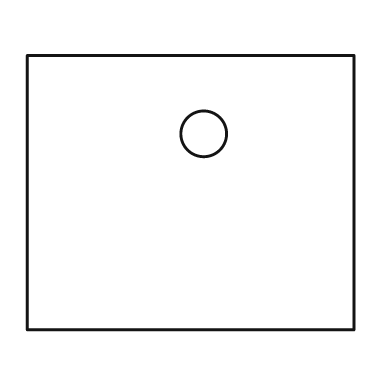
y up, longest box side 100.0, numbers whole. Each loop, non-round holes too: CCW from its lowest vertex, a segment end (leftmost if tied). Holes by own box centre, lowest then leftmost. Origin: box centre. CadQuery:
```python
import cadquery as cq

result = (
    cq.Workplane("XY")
    .moveTo(-50.0, -42.0)
    .lineTo(50.0, -42.0)
    .lineTo(50.0, 42.0)
    .lineTo(-50.0, 42.0)
    .close()
    .moveTo(4.0, 18.0)
    .circle(7.0)
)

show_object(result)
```